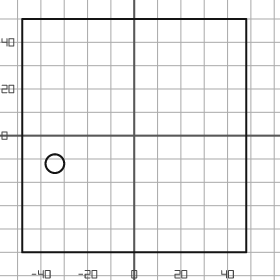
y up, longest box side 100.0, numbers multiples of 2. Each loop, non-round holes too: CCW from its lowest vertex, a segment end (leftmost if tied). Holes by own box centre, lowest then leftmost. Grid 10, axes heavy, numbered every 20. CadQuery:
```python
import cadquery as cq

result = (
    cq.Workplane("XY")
    .moveTo(-48.0, -50.0)
    .lineTo(48.0, -50.0)
    .lineTo(48.0, 50.0)
    .lineTo(-48.0, 50.0)
    .close()
    .moveTo(-34.0, -12.0)
    .circle(4.0)
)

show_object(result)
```